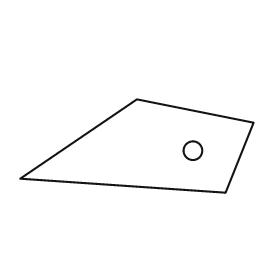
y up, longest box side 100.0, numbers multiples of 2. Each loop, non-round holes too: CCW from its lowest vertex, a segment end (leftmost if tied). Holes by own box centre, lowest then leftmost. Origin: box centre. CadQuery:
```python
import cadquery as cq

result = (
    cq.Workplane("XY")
    .moveTo(38.0, -20.0)
    .lineTo(50.0, 10.0)
    .lineTo(0.0, 20.0)
    .lineTo(-50.0, -14.0)
    .close()
    .moveTo(24.0, -2.0)
    .circle(4.0)
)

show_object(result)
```